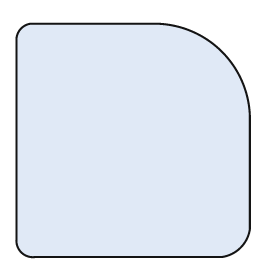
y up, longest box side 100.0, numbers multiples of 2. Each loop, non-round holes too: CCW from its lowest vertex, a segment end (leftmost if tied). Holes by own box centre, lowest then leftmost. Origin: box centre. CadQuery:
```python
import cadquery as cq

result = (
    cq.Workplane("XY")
    .moveTo(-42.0, -50.0)
    .lineTo(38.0, -50.0)
    .threePointArc((46.0, -46.0), (50.0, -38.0))
    .lineTo(50.0, 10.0)
    .threePointArc((38.0, 38.0), (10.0, 50.0))
    .lineTo(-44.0, 50.0)
    .threePointArc((-48.0, 48.0), (-50.0, 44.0))
    .lineTo(-50.0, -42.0)
    .threePointArc((-48.0, -48.0), (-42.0, -50.0))
    .close()
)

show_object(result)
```